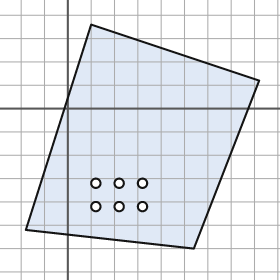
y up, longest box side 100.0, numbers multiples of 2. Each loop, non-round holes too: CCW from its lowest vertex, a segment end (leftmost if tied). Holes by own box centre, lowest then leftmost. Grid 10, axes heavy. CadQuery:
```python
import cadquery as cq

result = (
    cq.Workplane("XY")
    .moveTo(54.0, -60.0)
    .lineTo(82.0, 12.0)
    .lineTo(10.0, 36.0)
    .lineTo(-18.0, -52.0)
    .close()
    .moveTo(12.0, -42.0)
    .circle(2.0)
    .moveTo(22.0, -42.0)
    .circle(2.0)
    .moveTo(32.0, -42.0)
    .circle(2.0)
    .moveTo(12.0, -32.0)
    .circle(2.0)
    .moveTo(22.0, -32.0)
    .circle(2.0)
    .moveTo(32.0, -32.0)
    .circle(2.0)
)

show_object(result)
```